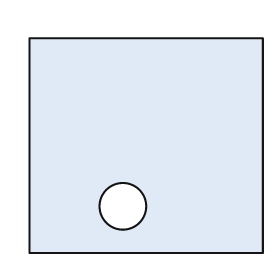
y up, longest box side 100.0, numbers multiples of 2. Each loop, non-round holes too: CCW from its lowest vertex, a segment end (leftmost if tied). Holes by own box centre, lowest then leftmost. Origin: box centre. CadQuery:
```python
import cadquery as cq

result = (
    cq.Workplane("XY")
    .moveTo(-50.0, -46.0)
    .lineTo(50.0, -46.0)
    .lineTo(50.0, 46.0)
    .lineTo(-50.0, 46.0)
    .close()
    .moveTo(-10.0, -26.0)
    .circle(10.0)
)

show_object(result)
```